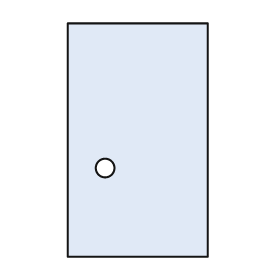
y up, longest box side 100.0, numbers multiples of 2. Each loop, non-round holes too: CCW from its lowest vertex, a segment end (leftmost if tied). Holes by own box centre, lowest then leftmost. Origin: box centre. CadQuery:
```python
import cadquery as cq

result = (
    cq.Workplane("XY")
    .moveTo(-30.0, -50.0)
    .lineTo(30.0, -50.0)
    .lineTo(30.0, 50.0)
    .lineTo(-30.0, 50.0)
    .close()
    .moveTo(-14.0, -12.0)
    .circle(4.0)
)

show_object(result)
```